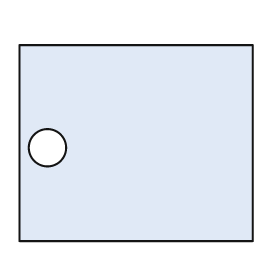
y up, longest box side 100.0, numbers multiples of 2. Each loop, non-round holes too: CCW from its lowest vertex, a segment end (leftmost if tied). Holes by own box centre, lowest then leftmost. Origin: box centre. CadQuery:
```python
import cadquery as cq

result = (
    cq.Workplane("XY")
    .moveTo(-50.0, -42.0)
    .lineTo(50.0, -42.0)
    .lineTo(50.0, 42.0)
    .lineTo(-50.0, 42.0)
    .close()
    .moveTo(-38.0, -2.0)
    .circle(8.0)
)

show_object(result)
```